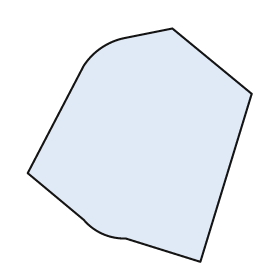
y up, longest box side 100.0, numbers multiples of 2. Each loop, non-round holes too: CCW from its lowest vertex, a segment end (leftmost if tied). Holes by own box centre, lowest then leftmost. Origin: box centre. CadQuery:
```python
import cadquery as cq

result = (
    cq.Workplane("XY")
    .moveTo(26.0, -50.0)
    .lineTo(48.0, 22.0)
    .lineTo(14.0, 50.0)
    .lineTo(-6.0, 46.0)
    .threePointArc((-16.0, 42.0), (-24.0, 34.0))
    .lineTo(-48.0, -12.0)
    .lineTo(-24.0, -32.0)
    .threePointArc((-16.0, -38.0), (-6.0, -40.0))
    .close()
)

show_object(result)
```